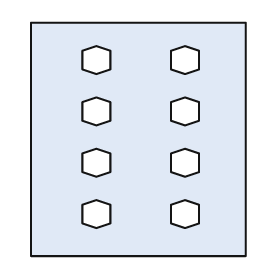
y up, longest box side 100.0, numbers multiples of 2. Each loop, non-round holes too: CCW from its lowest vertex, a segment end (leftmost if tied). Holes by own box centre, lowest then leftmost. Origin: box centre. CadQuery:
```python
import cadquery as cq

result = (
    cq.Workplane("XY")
    .moveTo(-46.0, -50.0)
    .lineTo(46.0, -50.0)
    .lineTo(46.0, 50.0)
    .lineTo(-46.0, 50.0)
    .close()
    .moveTo(-18.0, -38.0)
    .lineTo(-12.0, -36.0)
    .lineTo(-12.0, -28.0)
    .lineTo(-18.0, -26.0)
    .lineTo(-24.0, -28.0)
    .lineTo(-24.0, -36.0)
    .close()
    .moveTo(20.0, -38.0)
    .lineTo(26.0, -36.0)
    .lineTo(26.0, -28.0)
    .lineTo(20.0, -26.0)
    .lineTo(14.0, -28.0)
    .lineTo(14.0, -36.0)
    .close()
    .moveTo(-18.0, -16.0)
    .lineTo(-12.0, -14.0)
    .lineTo(-12.0, -6.0)
    .lineTo(-18.0, -4.0)
    .lineTo(-24.0, -6.0)
    .lineTo(-24.0, -14.0)
    .close()
    .moveTo(20.0, -16.0)
    .lineTo(26.0, -14.0)
    .lineTo(26.0, -6.0)
    .lineTo(20.0, -4.0)
    .lineTo(14.0, -6.0)
    .lineTo(14.0, -14.0)
    .close()
    .moveTo(-18.0, 6.0)
    .lineTo(-12.0, 8.0)
    .lineTo(-12.0, 16.0)
    .lineTo(-18.0, 18.0)
    .lineTo(-24.0, 16.0)
    .lineTo(-24.0, 8.0)
    .close()
    .moveTo(20.0, 6.0)
    .lineTo(26.0, 8.0)
    .lineTo(26.0, 16.0)
    .lineTo(20.0, 18.0)
    .lineTo(14.0, 16.0)
    .lineTo(14.0, 8.0)
    .close()
    .moveTo(-18.0, 28.0)
    .lineTo(-12.0, 30.0)
    .lineTo(-12.0, 38.0)
    .lineTo(-18.0, 40.0)
    .lineTo(-24.0, 38.0)
    .lineTo(-24.0, 30.0)
    .close()
    .moveTo(20.0, 28.0)
    .lineTo(26.0, 30.0)
    .lineTo(26.0, 38.0)
    .lineTo(20.0, 40.0)
    .lineTo(14.0, 38.0)
    .lineTo(14.0, 30.0)
    .close()
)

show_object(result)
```